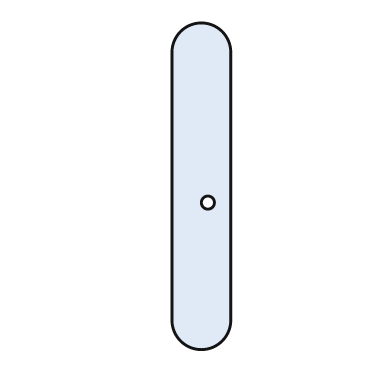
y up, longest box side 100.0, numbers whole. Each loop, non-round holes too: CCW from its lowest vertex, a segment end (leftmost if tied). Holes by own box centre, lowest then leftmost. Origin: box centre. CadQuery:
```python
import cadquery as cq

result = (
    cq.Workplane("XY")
    .moveTo(-9.0, -41.0)
    .threePointArc((0.0, -50.0), (9.0, -41.0))
    .lineTo(9.0, 41.0)
    .threePointArc((0.0, 50.0), (-9.0, 41.0))
    .close()
    .moveTo(2.0, -5.0)
    .circle(2.0)
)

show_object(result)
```